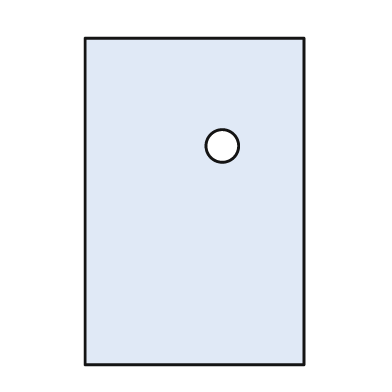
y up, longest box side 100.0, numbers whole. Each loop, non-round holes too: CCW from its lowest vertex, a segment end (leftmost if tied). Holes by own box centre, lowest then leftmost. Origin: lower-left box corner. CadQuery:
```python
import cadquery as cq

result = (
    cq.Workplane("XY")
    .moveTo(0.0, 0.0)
    .lineTo(67.0, 0.0)
    .lineTo(67.0, 100.0)
    .lineTo(0.0, 100.0)
    .close()
    .moveTo(42.0, 67.0)
    .circle(5.0)
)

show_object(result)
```